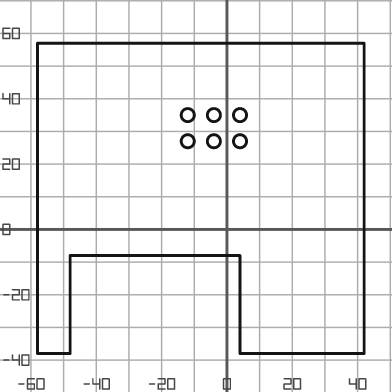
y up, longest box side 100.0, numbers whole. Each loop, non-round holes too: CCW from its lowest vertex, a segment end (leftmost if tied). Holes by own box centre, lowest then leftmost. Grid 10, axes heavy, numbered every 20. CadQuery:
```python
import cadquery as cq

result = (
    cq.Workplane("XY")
    .moveTo(-58.0, -38.0)
    .lineTo(-48.0, -38.0)
    .lineTo(-48.0, -8.0)
    .lineTo(4.0, -8.0)
    .lineTo(4.0, -38.0)
    .lineTo(42.0, -38.0)
    .lineTo(42.0, 57.0)
    .lineTo(-58.0, 57.0)
    .close()
    .moveTo(-12.0, 27.0)
    .circle(2.0)
    .moveTo(-4.0, 27.0)
    .circle(2.0)
    .moveTo(4.0, 27.0)
    .circle(2.0)
    .moveTo(-12.0, 35.0)
    .circle(2.0)
    .moveTo(-4.0, 35.0)
    .circle(2.0)
    .moveTo(4.0, 35.0)
    .circle(2.0)
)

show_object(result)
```